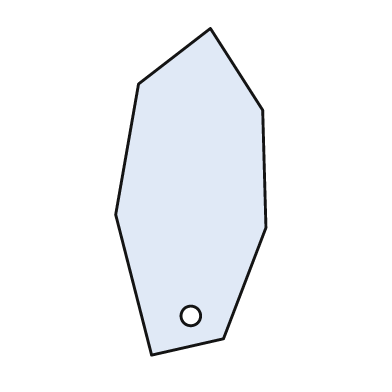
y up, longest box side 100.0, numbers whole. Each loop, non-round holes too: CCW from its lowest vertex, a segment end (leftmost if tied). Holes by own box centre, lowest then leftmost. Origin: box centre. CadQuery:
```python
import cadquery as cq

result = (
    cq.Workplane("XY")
    .moveTo(-12.0, -50.0)
    .lineTo(10.0, -45.0)
    .lineTo(23.0, -11.0)
    .lineTo(22.0, 25.0)
    .lineTo(6.0, 50.0)
    .lineTo(-16.0, 33.0)
    .lineTo(-23.0, -7.0)
    .close()
    .moveTo(0.0, -38.0)
    .circle(3.0)
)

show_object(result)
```